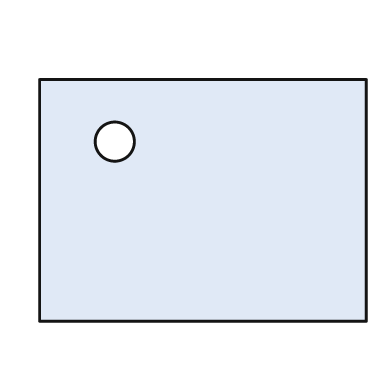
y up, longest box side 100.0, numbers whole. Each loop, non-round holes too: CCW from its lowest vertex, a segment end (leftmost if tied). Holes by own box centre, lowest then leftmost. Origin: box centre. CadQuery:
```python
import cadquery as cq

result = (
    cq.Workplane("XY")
    .moveTo(-50.0, -37.0)
    .lineTo(50.0, -37.0)
    .lineTo(50.0, 37.0)
    .lineTo(-50.0, 37.0)
    .close()
    .moveTo(-27.0, 18.0)
    .circle(6.0)
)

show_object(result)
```